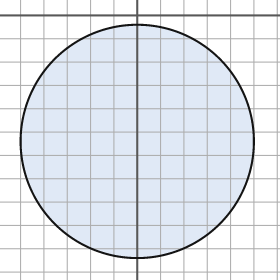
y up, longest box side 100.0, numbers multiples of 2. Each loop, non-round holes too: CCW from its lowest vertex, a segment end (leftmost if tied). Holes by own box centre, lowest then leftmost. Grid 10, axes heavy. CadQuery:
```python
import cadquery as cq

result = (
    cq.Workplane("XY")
    .moveTo(0.0, -54.0)
    .circle(50.0)
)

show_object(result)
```